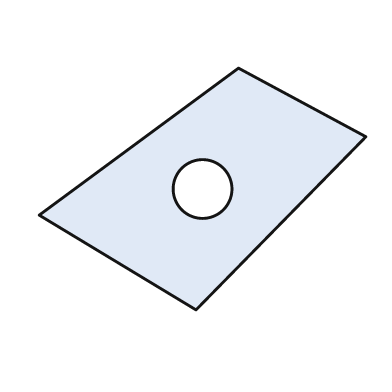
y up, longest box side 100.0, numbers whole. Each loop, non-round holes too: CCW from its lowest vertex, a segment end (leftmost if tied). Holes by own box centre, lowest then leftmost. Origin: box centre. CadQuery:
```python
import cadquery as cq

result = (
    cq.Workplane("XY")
    .moveTo(-2.0, -37.0)
    .lineTo(50.0, 16.0)
    .lineTo(11.0, 37.0)
    .lineTo(-50.0, -8.0)
    .close()
    .moveTo(0.0, 0.0)
    .circle(9.0)
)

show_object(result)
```